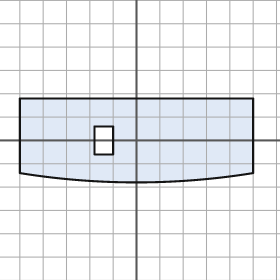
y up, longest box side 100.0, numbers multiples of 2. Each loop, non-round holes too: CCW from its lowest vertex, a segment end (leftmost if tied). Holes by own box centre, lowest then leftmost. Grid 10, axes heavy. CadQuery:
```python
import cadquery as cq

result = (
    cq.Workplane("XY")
    .moveTo(-50.0, -14.0)
    .threePointArc((0.0, -18.0), (50.0, -14.0))
    .lineTo(50.0, 18.0)
    .lineTo(-50.0, 18.0)
    .close()
    .moveTo(-18.0, -6.0)
    .lineTo(-10.0, -6.0)
    .lineTo(-10.0, 6.0)
    .lineTo(-18.0, 6.0)
    .close()
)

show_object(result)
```